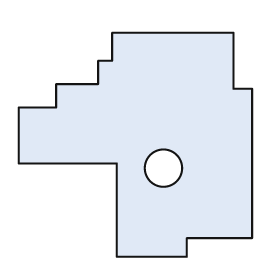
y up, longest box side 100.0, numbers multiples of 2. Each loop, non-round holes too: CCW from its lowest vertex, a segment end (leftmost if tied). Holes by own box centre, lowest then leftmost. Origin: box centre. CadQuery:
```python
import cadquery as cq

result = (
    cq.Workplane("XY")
    .moveTo(-8.0, -48.0)
    .lineTo(22.0, -48.0)
    .lineTo(22.0, -40.0)
    .lineTo(50.0, -40.0)
    .lineTo(50.0, 24.0)
    .lineTo(42.0, 24.0)
    .lineTo(42.0, 48.0)
    .lineTo(-10.0, 48.0)
    .lineTo(-10.0, 36.0)
    .lineTo(-16.0, 36.0)
    .lineTo(-16.0, 26.0)
    .lineTo(-34.0, 26.0)
    .lineTo(-34.0, 16.0)
    .lineTo(-50.0, 16.0)
    .lineTo(-50.0, -8.0)
    .lineTo(-8.0, -8.0)
    .close()
    .moveTo(12.0, -10.0)
    .circle(8.0)
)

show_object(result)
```